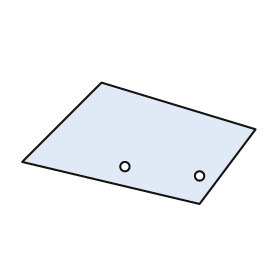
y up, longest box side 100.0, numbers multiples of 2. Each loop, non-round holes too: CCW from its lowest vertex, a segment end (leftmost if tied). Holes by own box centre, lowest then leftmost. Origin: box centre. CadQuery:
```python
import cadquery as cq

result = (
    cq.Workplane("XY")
    .moveTo(26.0, -26.0)
    .lineTo(50.0, 6.0)
    .lineTo(-16.0, 26.0)
    .lineTo(-50.0, -8.0)
    .close()
    .moveTo(26.0, -14.0)
    .circle(2.0)
    .moveTo(-6.0, -10.0)
    .circle(2.0)
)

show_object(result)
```